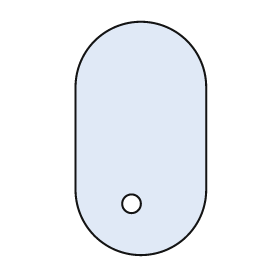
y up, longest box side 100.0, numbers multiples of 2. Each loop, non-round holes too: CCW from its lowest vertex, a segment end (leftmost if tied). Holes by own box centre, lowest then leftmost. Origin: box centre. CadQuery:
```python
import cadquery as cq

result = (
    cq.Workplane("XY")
    .moveTo(-28.0, -22.0)
    .threePointArc((0.0, -50.0), (28.0, -22.0))
    .lineTo(28.0, 22.0)
    .threePointArc((0.0, 50.0), (-28.0, 22.0))
    .close()
    .moveTo(-4.0, -28.0)
    .circle(4.0)
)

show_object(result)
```